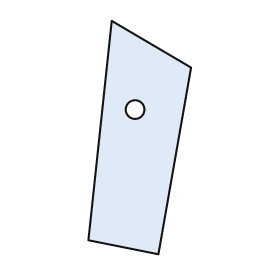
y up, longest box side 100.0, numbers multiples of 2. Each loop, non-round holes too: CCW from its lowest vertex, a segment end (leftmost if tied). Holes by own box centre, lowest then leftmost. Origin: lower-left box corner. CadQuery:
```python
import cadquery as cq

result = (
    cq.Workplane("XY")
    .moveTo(30.0, 0.0)
    .lineTo(44.0, 80.0)
    .lineTo(10.0, 100.0)
    .lineTo(0.0, 6.0)
    .close()
    .moveTo(20.0, 62.0)
    .circle(4.0)
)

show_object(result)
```